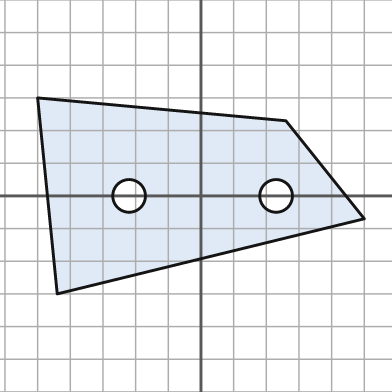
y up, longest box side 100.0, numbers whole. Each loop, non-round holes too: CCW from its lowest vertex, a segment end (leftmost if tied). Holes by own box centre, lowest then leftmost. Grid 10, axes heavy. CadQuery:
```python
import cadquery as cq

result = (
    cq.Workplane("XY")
    .moveTo(-44.0, -30.0)
    .lineTo(50.0, -7.0)
    .lineTo(26.0, 23.0)
    .lineTo(-50.0, 30.0)
    .close()
    .moveTo(-22.0, 0.0)
    .circle(5.0)
    .moveTo(23.0, 0.0)
    .circle(5.0)
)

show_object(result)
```